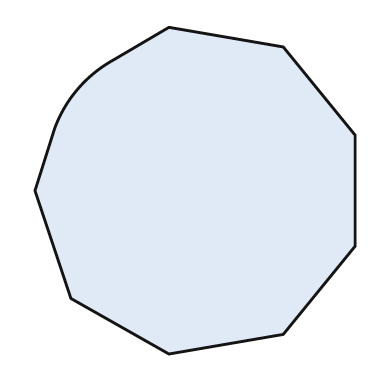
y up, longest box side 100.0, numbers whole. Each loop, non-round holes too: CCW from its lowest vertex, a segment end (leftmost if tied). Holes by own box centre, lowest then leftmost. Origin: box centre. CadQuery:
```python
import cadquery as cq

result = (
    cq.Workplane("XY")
    .moveTo(-8.0, -50.0)
    .lineTo(27.0, -44.0)
    .lineTo(49.0, -17.0)
    .lineTo(49.0, 17.0)
    .lineTo(27.0, 44.0)
    .lineTo(-8.0, 50.0)
    .lineTo(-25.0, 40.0)
    .threePointArc((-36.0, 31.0), (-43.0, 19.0))
    .lineTo(-49.0, 0.0)
    .lineTo(-38.0, -33.0)
    .close()
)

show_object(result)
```